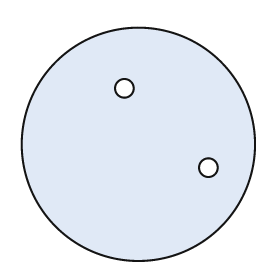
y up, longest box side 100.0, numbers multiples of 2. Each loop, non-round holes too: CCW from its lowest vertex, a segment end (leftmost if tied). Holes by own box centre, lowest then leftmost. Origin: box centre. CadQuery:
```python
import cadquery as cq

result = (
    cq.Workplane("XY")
    .moveTo(0.0, 0.0)
    .circle(50.0)
    .moveTo(30.0, -10.0)
    .circle(4.0)
    .moveTo(-6.0, 24.0)
    .circle(4.0)
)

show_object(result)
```